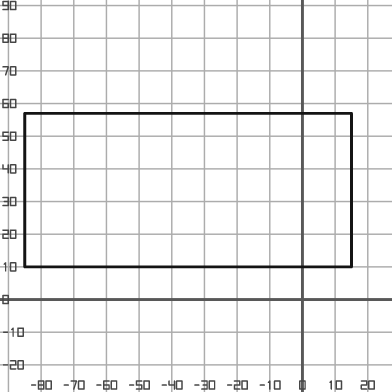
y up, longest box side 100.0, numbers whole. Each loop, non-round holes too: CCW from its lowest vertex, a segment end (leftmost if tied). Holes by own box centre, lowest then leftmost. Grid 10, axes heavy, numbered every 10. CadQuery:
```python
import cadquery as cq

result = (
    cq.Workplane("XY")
    .moveTo(-85.0, 10.0)
    .lineTo(15.0, 10.0)
    .lineTo(15.0, 57.0)
    .lineTo(-85.0, 57.0)
    .close()
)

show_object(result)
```